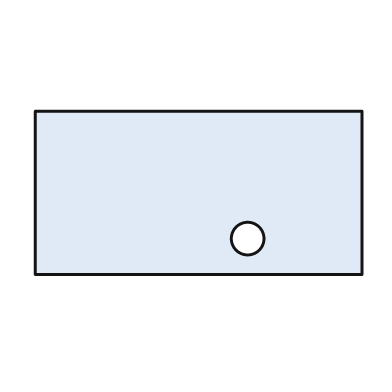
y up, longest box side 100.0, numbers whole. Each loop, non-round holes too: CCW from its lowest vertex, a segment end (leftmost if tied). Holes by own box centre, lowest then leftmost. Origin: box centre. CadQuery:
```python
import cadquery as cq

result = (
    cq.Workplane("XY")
    .moveTo(-50.0, -25.0)
    .lineTo(50.0, -25.0)
    .lineTo(50.0, 25.0)
    .lineTo(-50.0, 25.0)
    .close()
    .moveTo(15.0, -14.0)
    .circle(5.0)
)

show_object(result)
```